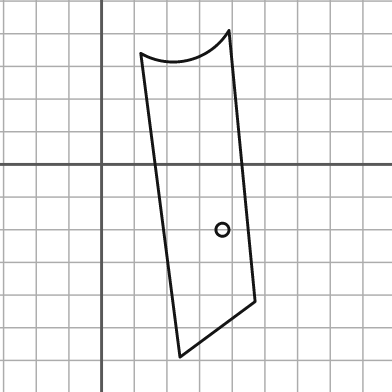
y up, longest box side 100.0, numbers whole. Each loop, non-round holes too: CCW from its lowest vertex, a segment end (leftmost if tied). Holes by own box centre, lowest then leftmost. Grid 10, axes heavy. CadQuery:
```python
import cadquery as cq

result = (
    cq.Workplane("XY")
    .moveTo(24.0, -59.0)
    .lineTo(47.0, -42.0)
    .lineTo(39.0, 41.0)
    .threePointArc((27.0, 32.0), (12.0, 34.0))
    .close()
    .moveTo(37.0, -20.0)
    .circle(2.0)
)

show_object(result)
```